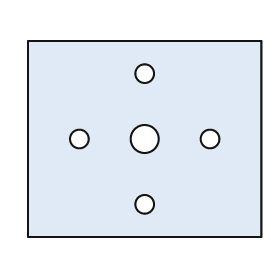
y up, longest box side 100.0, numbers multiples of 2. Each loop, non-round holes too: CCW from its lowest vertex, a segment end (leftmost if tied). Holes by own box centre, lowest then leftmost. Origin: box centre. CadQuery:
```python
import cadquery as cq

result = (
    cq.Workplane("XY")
    .moveTo(-50.0, -42.0)
    .lineTo(50.0, -42.0)
    .lineTo(50.0, 42.0)
    .lineTo(-50.0, 42.0)
    .close()
    .moveTo(0.0, -28.0)
    .circle(4.0)
    .moveTo(-28.0, 0.0)
    .circle(4.0)
    .moveTo(0.0, 0.0)
    .circle(6.0)
    .moveTo(28.0, 0.0)
    .circle(4.0)
    .moveTo(0.0, 28.0)
    .circle(4.0)
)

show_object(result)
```